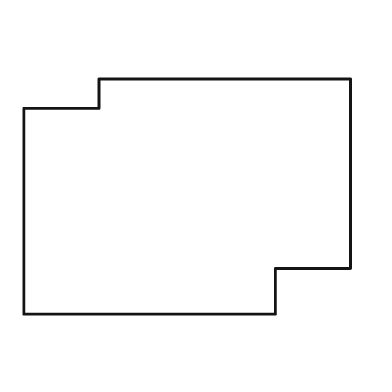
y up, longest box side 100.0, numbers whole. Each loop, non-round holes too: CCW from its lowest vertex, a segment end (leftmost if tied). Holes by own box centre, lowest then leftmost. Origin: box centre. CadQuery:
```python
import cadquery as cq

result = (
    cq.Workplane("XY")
    .moveTo(-50.0, -36.0)
    .lineTo(27.0, -36.0)
    .lineTo(27.0, -22.0)
    .lineTo(50.0, -22.0)
    .lineTo(50.0, 36.0)
    .lineTo(-27.0, 36.0)
    .lineTo(-27.0, 27.0)
    .lineTo(-50.0, 27.0)
    .close()
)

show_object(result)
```